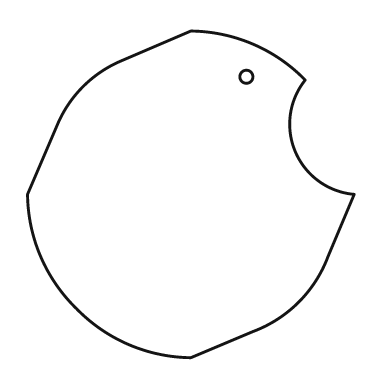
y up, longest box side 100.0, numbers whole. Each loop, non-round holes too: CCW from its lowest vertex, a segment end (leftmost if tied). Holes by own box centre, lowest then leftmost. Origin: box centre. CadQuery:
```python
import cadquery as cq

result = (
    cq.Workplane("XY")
    .moveTo(0.0, -50.0)
    .lineTo(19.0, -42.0)
    .threePointArc((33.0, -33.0), (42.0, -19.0))
    .lineTo(50.0, 0.0)
    .threePointArc((32.0, 13.0), (35.0, 35.0))
    .threePointArc((19.0, 46.0), (0.0, 50.0))
    .lineTo(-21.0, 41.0)
    .threePointArc((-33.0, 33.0), (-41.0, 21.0))
    .lineTo(-50.0, 0.0)
    .threePointArc((-46.0, -19.0), (-35.0, -35.0))
    .threePointArc((-19.0, -46.0), (0.0, -50.0))
    .close()
    .moveTo(17.0, 36.0)
    .circle(2.0)
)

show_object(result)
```